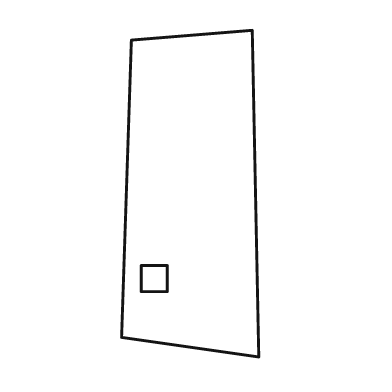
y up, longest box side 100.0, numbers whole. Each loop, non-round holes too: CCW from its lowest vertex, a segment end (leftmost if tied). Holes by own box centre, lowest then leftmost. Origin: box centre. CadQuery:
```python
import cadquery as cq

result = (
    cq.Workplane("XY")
    .moveTo(21.0, -50.0)
    .lineTo(19.0, 50.0)
    .lineTo(-18.0, 47.0)
    .lineTo(-21.0, -44.0)
    .close()
    .moveTo(-15.0, -30.0)
    .lineTo(-7.0, -30.0)
    .lineTo(-7.0, -22.0)
    .lineTo(-15.0, -22.0)
    .close()
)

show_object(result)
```